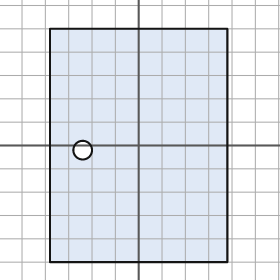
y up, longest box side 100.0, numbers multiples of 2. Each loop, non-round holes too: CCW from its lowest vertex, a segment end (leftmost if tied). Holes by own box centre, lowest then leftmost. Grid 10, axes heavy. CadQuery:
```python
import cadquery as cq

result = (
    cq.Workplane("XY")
    .moveTo(-38.0, -50.0)
    .lineTo(38.0, -50.0)
    .lineTo(38.0, 50.0)
    .lineTo(-38.0, 50.0)
    .close()
    .moveTo(-24.0, -2.0)
    .circle(4.0)
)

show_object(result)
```